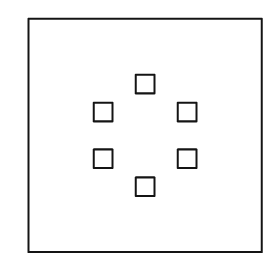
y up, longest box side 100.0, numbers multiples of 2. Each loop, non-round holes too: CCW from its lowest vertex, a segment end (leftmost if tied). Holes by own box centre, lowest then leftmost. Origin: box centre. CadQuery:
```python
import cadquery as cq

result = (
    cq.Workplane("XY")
    .moveTo(-50.0, -50.0)
    .lineTo(50.0, -50.0)
    .lineTo(50.0, 50.0)
    .lineTo(-50.0, 50.0)
    .close()
    .moveTo(-4.0, -26.0)
    .lineTo(4.0, -26.0)
    .lineTo(4.0, -18.0)
    .lineTo(-4.0, -18.0)
    .close()
    .moveTo(-22.0, -14.0)
    .lineTo(-14.0, -14.0)
    .lineTo(-14.0, -6.0)
    .lineTo(-22.0, -6.0)
    .close()
    .moveTo(14.0, -14.0)
    .lineTo(22.0, -14.0)
    .lineTo(22.0, -6.0)
    .lineTo(14.0, -6.0)
    .close()
    .moveTo(-22.0, 6.0)
    .lineTo(-14.0, 6.0)
    .lineTo(-14.0, 14.0)
    .lineTo(-22.0, 14.0)
    .close()
    .moveTo(14.0, 6.0)
    .lineTo(22.0, 6.0)
    .lineTo(22.0, 14.0)
    .lineTo(14.0, 14.0)
    .close()
    .moveTo(-4.0, 18.0)
    .lineTo(4.0, 18.0)
    .lineTo(4.0, 26.0)
    .lineTo(-4.0, 26.0)
    .close()
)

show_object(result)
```